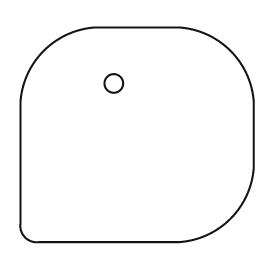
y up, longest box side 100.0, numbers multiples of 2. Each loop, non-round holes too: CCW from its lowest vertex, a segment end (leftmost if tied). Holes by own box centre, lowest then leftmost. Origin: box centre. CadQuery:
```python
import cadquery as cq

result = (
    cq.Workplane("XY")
    .moveTo(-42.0, -46.0)
    .lineTo(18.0, -46.0)
    .threePointArc((40.0, -36.0), (50.0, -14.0))
    .lineTo(50.0, 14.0)
    .threePointArc((40.0, 36.0), (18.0, 46.0))
    .lineTo(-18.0, 46.0)
    .threePointArc((-40.0, 36.0), (-50.0, 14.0))
    .lineTo(-50.0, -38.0)
    .threePointArc((-48.0, -44.0), (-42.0, -46.0))
    .close()
    .moveTo(-10.0, 22.0)
    .circle(4.0)
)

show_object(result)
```